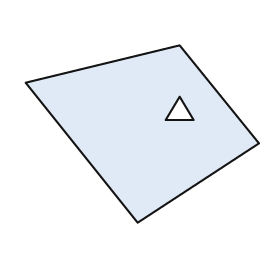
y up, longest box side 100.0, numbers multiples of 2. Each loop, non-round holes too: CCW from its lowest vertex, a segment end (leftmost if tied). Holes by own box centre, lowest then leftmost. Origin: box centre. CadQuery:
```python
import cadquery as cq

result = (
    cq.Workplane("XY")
    .moveTo(-2.0, -38.0)
    .lineTo(50.0, -4.0)
    .lineTo(16.0, 38.0)
    .lineTo(-50.0, 22.0)
    .close()
    .moveTo(10.0, 6.0)
    .lineTo(22.0, 6.0)
    .lineTo(16.0, 16.0)
    .close()
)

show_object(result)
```